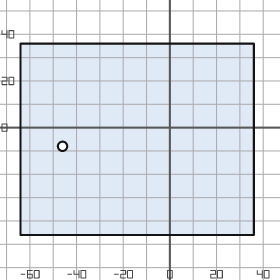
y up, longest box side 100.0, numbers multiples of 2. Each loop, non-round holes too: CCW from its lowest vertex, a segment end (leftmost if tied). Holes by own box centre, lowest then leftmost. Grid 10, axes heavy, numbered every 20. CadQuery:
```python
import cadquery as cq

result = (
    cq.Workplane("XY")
    .moveTo(-64.0, -46.0)
    .lineTo(36.0, -46.0)
    .lineTo(36.0, 36.0)
    .lineTo(-64.0, 36.0)
    .close()
    .moveTo(-46.0, -8.0)
    .circle(2.0)
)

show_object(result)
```